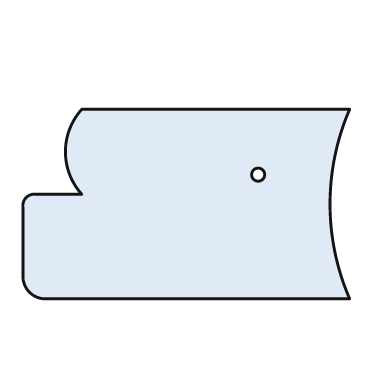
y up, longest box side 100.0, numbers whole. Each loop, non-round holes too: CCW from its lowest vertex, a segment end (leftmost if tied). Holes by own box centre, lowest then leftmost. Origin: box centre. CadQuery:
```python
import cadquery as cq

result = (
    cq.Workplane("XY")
    .moveTo(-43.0, -29.0)
    .lineTo(50.0, -29.0)
    .threePointArc((44.0, 0.0), (50.0, 29.0))
    .lineTo(-32.0, 29.0)
    .threePointArc((-37.0, 16.0), (-32.0, 3.0))
    .lineTo(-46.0, 3.0)
    .threePointArc((-49.0, 2.0), (-50.0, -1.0))
    .lineTo(-50.0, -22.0)
    .threePointArc((-48.0, -27.0), (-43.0, -29.0))
    .close()
    .moveTo(22.0, 9.0)
    .circle(2.0)
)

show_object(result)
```